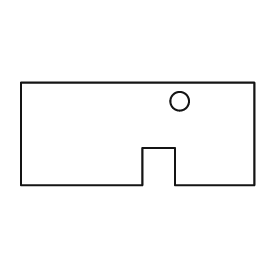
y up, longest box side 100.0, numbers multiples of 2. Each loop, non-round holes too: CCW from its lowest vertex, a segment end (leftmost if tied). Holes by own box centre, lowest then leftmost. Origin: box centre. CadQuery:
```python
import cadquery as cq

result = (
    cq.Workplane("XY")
    .moveTo(-50.0, -22.0)
    .lineTo(2.0, -22.0)
    .lineTo(2.0, -6.0)
    .lineTo(16.0, -6.0)
    .lineTo(16.0, -22.0)
    .lineTo(50.0, -22.0)
    .lineTo(50.0, 22.0)
    .lineTo(-50.0, 22.0)
    .close()
    .moveTo(18.0, 14.0)
    .circle(4.0)
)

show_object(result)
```